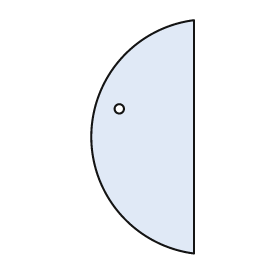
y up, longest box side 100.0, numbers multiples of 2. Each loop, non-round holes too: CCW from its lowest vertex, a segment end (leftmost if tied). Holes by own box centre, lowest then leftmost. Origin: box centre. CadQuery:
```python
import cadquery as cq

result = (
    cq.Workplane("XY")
    .moveTo(22.0, -50.0)
    .lineTo(22.0, 50.0)
    .threePointArc((-22.0, 0.0), (22.0, -50.0))
    .close()
    .moveTo(-10.0, 12.0)
    .circle(2.0)
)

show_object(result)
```